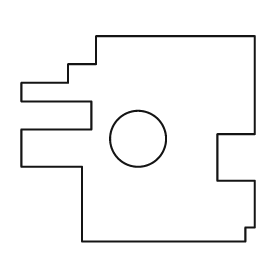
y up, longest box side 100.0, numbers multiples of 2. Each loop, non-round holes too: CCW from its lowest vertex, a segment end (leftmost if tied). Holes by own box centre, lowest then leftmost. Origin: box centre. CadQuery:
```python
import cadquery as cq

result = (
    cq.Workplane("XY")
    .moveTo(-24.0, -44.0)
    .lineTo(46.0, -44.0)
    .lineTo(46.0, -38.0)
    .lineTo(50.0, -38.0)
    .lineTo(50.0, -18.0)
    .lineTo(34.0, -18.0)
    .lineTo(34.0, 2.0)
    .lineTo(50.0, 2.0)
    .lineTo(50.0, 44.0)
    .lineTo(-18.0, 44.0)
    .lineTo(-18.0, 32.0)
    .lineTo(-30.0, 32.0)
    .lineTo(-30.0, 24.0)
    .lineTo(-50.0, 24.0)
    .lineTo(-50.0, 16.0)
    .lineTo(-20.0, 16.0)
    .lineTo(-20.0, 4.0)
    .lineTo(-50.0, 4.0)
    .lineTo(-50.0, -12.0)
    .lineTo(-24.0, -12.0)
    .close()
    .moveTo(0.0, 0.0)
    .circle(12.0)
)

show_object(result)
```